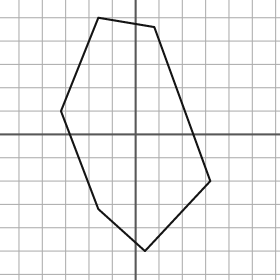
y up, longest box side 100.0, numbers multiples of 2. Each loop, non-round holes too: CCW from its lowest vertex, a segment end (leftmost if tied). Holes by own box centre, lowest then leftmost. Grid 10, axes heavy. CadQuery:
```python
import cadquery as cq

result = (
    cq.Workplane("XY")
    .moveTo(4.0, -50.0)
    .lineTo(32.0, -20.0)
    .lineTo(8.0, 46.0)
    .lineTo(-16.0, 50.0)
    .lineTo(-32.0, 10.0)
    .lineTo(-16.0, -32.0)
    .close()
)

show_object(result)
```